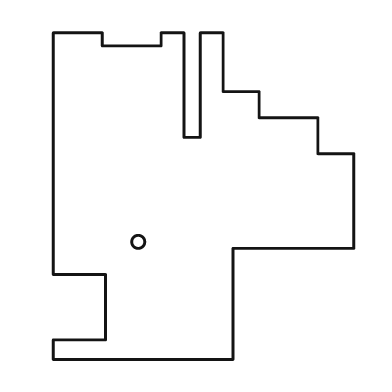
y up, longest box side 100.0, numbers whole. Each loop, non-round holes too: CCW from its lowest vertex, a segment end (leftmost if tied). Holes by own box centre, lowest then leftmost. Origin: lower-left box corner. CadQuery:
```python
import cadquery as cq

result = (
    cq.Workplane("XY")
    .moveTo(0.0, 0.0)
    .lineTo(55.0, 0.0)
    .lineTo(55.0, 34.0)
    .lineTo(92.0, 34.0)
    .lineTo(92.0, 63.0)
    .lineTo(81.0, 63.0)
    .lineTo(81.0, 74.0)
    .lineTo(63.0, 74.0)
    .lineTo(63.0, 82.0)
    .lineTo(52.0, 82.0)
    .lineTo(52.0, 100.0)
    .lineTo(45.0, 100.0)
    .lineTo(45.0, 68.0)
    .lineTo(40.0, 68.0)
    .lineTo(40.0, 100.0)
    .lineTo(33.0, 100.0)
    .lineTo(33.0, 96.0)
    .lineTo(15.0, 96.0)
    .lineTo(15.0, 100.0)
    .lineTo(0.0, 100.0)
    .lineTo(0.0, 26.0)
    .lineTo(16.0, 26.0)
    .lineTo(16.0, 6.0)
    .lineTo(0.0, 6.0)
    .close()
    .moveTo(26.0, 36.0)
    .circle(2.0)
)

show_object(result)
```